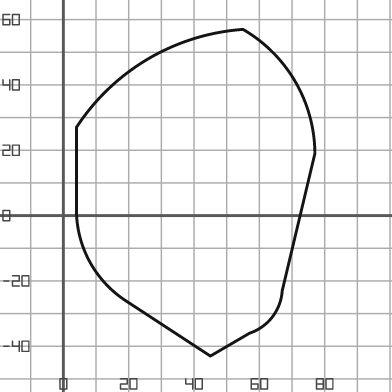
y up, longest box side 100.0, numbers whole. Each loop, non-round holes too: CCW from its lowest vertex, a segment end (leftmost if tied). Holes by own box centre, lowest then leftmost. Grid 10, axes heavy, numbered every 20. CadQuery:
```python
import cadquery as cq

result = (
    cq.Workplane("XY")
    .moveTo(45.0, -43.0)
    .lineTo(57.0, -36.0)
    .threePointArc((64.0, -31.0), (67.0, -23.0))
    .lineTo(77.0, 19.0)
    .threePointArc((71.0, 41.0), (55.0, 57.0))
    .threePointArc((26.0, 48.0), (4.0, 27.0))
    .lineTo(4.0, 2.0)
    .threePointArc((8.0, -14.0), (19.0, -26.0))
    .close()
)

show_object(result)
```